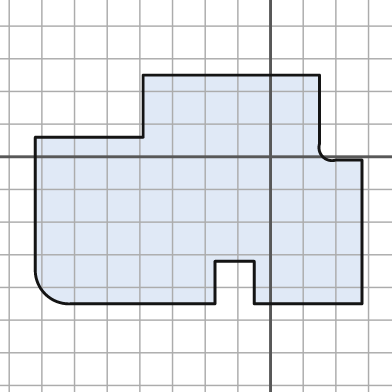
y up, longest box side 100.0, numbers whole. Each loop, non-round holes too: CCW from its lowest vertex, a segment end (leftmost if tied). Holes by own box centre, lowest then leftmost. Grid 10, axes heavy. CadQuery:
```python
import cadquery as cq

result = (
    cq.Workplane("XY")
    .moveTo(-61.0, -45.0)
    .lineTo(-17.0, -45.0)
    .lineTo(-17.0, -32.0)
    .lineTo(-5.0, -32.0)
    .lineTo(-5.0, -45.0)
    .lineTo(28.0, -45.0)
    .lineTo(28.0, -1.0)
    .lineTo(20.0, -1.0)
    .threePointArc((16.0, 0.0), (15.0, 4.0))
    .lineTo(15.0, 25.0)
    .lineTo(-39.0, 25.0)
    .lineTo(-39.0, 6.0)
    .lineTo(-72.0, 6.0)
    .lineTo(-72.0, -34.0)
    .threePointArc((-69.0, -42.0), (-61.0, -45.0))
    .close()
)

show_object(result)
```